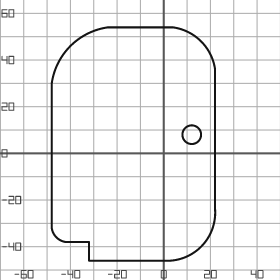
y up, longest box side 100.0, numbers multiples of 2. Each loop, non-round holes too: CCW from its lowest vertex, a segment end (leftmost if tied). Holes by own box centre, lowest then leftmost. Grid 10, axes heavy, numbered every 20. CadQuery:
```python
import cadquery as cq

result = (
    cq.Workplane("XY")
    .moveTo(-32.0, -46.0)
    .lineTo(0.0, -46.0)
    .threePointArc((16.0, -40.0), (22.0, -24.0))
    .lineTo(22.0, 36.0)
    .threePointArc((16.0, 48.0), (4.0, 54.0))
    .lineTo(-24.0, 54.0)
    .threePointArc((-40.0, 46.0), (-48.0, 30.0))
    .lineTo(-48.0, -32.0)
    .threePointArc((-46.0, -36.0), (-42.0, -38.0))
    .lineTo(-32.0, -38.0)
    .close()
    .moveTo(12.0, 8.0)
    .circle(4.0)
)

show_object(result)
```